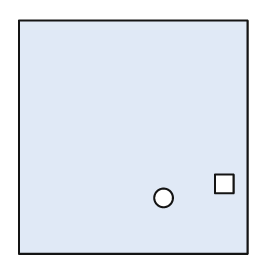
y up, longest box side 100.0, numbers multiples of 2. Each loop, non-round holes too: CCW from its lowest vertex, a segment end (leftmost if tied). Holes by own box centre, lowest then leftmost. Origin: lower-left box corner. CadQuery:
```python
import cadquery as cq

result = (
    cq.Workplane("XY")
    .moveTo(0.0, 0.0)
    .lineTo(98.0, 0.0)
    .lineTo(98.0, 100.0)
    .lineTo(0.0, 100.0)
    .close()
    .moveTo(62.0, 24.0)
    .circle(4.0)
    .moveTo(84.0, 26.0)
    .lineTo(92.0, 26.0)
    .lineTo(92.0, 34.0)
    .lineTo(84.0, 34.0)
    .close()
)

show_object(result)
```